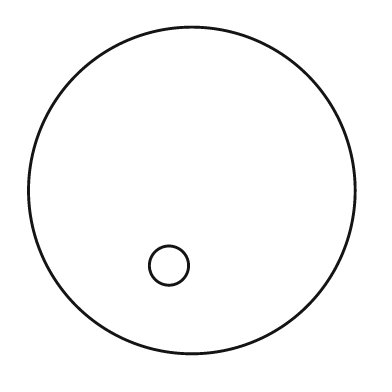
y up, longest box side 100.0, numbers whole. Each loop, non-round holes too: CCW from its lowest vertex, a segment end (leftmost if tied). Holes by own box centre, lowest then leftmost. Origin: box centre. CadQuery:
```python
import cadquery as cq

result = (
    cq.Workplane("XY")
    .moveTo(0.0, 0.0)
    .circle(50.0)
    .moveTo(-7.0, -23.0)
    .circle(6.0)
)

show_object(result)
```